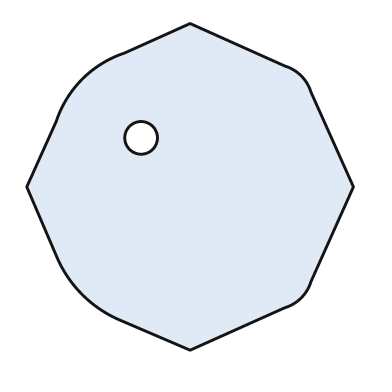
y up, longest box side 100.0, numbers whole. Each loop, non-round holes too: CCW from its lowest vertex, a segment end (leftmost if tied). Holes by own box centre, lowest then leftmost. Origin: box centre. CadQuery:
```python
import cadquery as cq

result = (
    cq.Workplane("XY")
    .moveTo(0.0, -50.0)
    .lineTo(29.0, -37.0)
    .threePointArc((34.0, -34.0), (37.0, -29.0))
    .lineTo(50.0, 0.0)
    .lineTo(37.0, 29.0)
    .threePointArc((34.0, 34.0), (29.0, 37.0))
    .lineTo(0.0, 50.0)
    .lineTo(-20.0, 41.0)
    .threePointArc((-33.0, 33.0), (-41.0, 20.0))
    .lineTo(-50.0, 0.0)
    .lineTo(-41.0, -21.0)
    .threePointArc((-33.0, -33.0), (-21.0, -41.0))
    .close()
    .moveTo(-15.0, 15.0)
    .circle(5.0)
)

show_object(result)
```